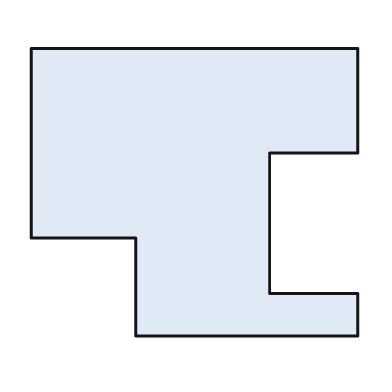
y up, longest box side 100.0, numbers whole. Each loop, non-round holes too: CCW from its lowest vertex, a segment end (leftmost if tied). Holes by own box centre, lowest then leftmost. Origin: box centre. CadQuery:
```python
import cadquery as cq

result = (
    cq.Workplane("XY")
    .moveTo(-18.0, -44.0)
    .lineTo(50.0, -44.0)
    .lineTo(50.0, -31.0)
    .lineTo(23.0, -31.0)
    .lineTo(23.0, 12.0)
    .lineTo(50.0, 12.0)
    .lineTo(50.0, 44.0)
    .lineTo(-50.0, 44.0)
    .lineTo(-50.0, -14.0)
    .lineTo(-18.0, -14.0)
    .close()
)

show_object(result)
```